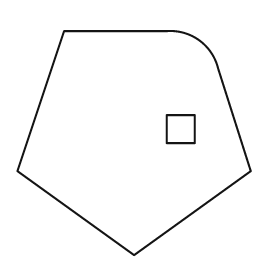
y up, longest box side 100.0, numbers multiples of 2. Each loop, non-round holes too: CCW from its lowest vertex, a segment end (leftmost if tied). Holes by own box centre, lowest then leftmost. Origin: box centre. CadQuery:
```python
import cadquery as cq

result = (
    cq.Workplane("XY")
    .moveTo(0.0, -48.0)
    .lineTo(50.0, -12.0)
    .lineTo(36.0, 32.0)
    .threePointArc((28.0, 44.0), (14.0, 48.0))
    .lineTo(-30.0, 48.0)
    .lineTo(-50.0, -12.0)
    .close()
    .moveTo(14.0, 0.0)
    .lineTo(26.0, 0.0)
    .lineTo(26.0, 12.0)
    .lineTo(14.0, 12.0)
    .close()
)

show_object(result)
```